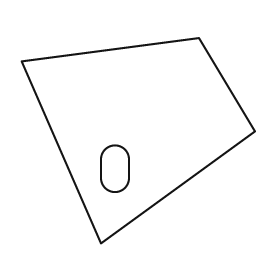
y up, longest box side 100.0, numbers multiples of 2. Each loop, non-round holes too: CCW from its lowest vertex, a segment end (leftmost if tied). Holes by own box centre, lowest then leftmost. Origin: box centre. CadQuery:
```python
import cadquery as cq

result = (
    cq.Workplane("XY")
    .moveTo(-16.0, -44.0)
    .lineTo(50.0, 4.0)
    .lineTo(26.0, 44.0)
    .lineTo(-50.0, 34.0)
    .close()
    .moveTo(-16.0, -16.0)
    .threePointArc((-10.0, -22.0), (-4.0, -16.0))
    .lineTo(-4.0, -8.0)
    .threePointArc((-10.0, -2.0), (-16.0, -8.0))
    .close()
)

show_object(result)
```